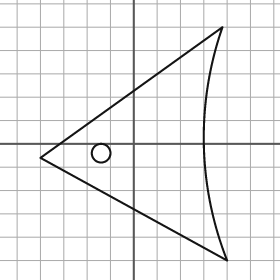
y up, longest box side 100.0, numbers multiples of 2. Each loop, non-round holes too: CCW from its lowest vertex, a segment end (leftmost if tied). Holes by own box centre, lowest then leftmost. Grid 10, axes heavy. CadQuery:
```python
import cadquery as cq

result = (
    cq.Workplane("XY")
    .moveTo(40.0, -50.0)
    .threePointArc((30.0, 0.0), (38.0, 50.0))
    .lineTo(-40.0, -6.0)
    .close()
    .moveTo(-14.0, -4.0)
    .circle(4.0)
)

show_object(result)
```